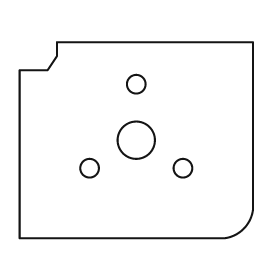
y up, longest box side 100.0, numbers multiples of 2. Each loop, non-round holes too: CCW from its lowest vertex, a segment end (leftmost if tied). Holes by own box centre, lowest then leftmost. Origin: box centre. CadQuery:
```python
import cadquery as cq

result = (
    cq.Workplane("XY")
    .moveTo(-50.0, -42.0)
    .lineTo(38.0, -42.0)
    .threePointArc((46.0, -38.0), (50.0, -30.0))
    .lineTo(50.0, 42.0)
    .lineTo(-34.0, 42.0)
    .lineTo(-34.0, 36.0)
    .lineTo(-38.0, 30.0)
    .lineTo(-50.0, 30.0)
    .close()
    .moveTo(-20.0, -12.0)
    .circle(4.0)
    .moveTo(20.0, -12.0)
    .circle(4.0)
    .moveTo(0.0, 0.0)
    .circle(8.0)
    .moveTo(0.0, 24.0)
    .circle(4.0)
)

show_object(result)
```